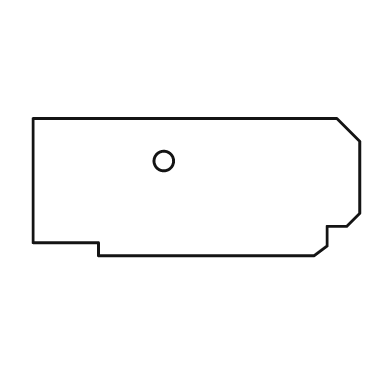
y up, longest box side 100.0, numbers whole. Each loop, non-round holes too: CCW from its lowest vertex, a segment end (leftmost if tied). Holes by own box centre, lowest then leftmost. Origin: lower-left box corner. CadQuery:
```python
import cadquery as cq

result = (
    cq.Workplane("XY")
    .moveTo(20.0, 0.0)
    .lineTo(86.0, 0.0)
    .lineTo(90.0, 3.0)
    .lineTo(90.0, 9.0)
    .lineTo(96.0, 9.0)
    .lineTo(100.0, 13.0)
    .lineTo(100.0, 35.0)
    .lineTo(93.0, 42.0)
    .lineTo(0.0, 42.0)
    .lineTo(0.0, 4.0)
    .lineTo(20.0, 4.0)
    .close()
    .moveTo(40.0, 29.0)
    .circle(3.0)
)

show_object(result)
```